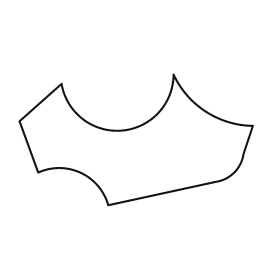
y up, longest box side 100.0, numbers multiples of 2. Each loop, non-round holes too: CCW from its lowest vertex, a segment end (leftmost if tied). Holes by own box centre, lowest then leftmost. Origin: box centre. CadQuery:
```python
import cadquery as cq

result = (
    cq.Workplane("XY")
    .moveTo(-12.0, -28.0)
    .lineTo(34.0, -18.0)
    .threePointArc((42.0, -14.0), (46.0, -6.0))
    .lineTo(50.0, 6.0)
    .threePointArc((30.0, 12.0), (16.0, 28.0))
    .threePointArc((-6.0, 4.0), (-32.0, 24.0))
    .lineTo(-50.0, 8.0)
    .lineTo(-42.0, -14.0)
    .threePointArc((-24.0, -14.0), (-12.0, -28.0))
    .close()
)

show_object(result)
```